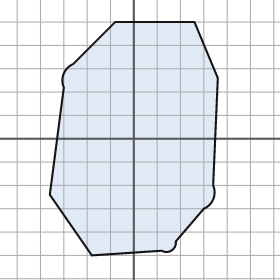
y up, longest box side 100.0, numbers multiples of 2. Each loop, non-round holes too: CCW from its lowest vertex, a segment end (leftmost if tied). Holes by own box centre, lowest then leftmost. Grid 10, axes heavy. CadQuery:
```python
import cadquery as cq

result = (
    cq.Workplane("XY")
    .moveTo(-18.0, -50.0)
    .lineTo(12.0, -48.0)
    .threePointArc((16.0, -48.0), (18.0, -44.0))
    .lineTo(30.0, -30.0)
    .threePointArc((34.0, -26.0), (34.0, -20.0))
    .lineTo(36.0, 26.0)
    .lineTo(26.0, 50.0)
    .lineTo(-8.0, 50.0)
    .lineTo(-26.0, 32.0)
    .threePointArc((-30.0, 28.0), (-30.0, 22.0))
    .lineTo(-36.0, -24.0)
    .close()
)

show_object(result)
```